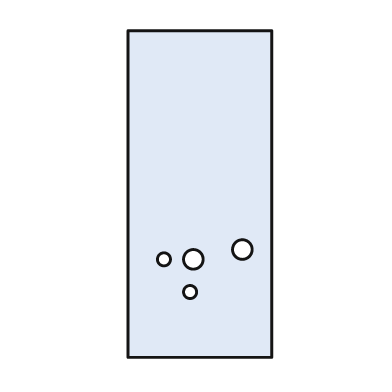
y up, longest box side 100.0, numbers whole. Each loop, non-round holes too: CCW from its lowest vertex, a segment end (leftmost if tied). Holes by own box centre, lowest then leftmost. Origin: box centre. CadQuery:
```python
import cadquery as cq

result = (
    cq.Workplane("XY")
    .moveTo(-22.0, -50.0)
    .lineTo(22.0, -50.0)
    .lineTo(22.0, 50.0)
    .lineTo(-22.0, 50.0)
    .close()
    .moveTo(-3.0, -30.0)
    .circle(2.0)
    .moveTo(-11.0, -20.0)
    .circle(2.0)
    .moveTo(-2.0, -20.0)
    .circle(3.0)
    .moveTo(13.0, -17.0)
    .circle(3.0)
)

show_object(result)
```